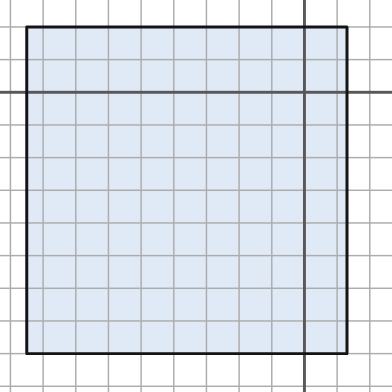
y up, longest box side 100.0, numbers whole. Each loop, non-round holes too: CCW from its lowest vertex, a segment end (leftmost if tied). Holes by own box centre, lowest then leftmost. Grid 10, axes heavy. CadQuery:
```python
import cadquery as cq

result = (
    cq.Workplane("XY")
    .moveTo(-85.0, -80.0)
    .lineTo(13.0, -80.0)
    .lineTo(13.0, 20.0)
    .lineTo(-85.0, 20.0)
    .close()
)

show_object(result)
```